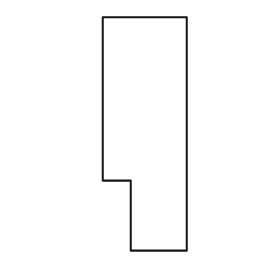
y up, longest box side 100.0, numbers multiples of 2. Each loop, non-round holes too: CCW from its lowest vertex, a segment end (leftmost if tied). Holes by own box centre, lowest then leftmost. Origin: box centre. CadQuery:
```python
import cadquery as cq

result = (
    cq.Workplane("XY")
    .moveTo(-6.0, -50.0)
    .lineTo(18.0, -50.0)
    .lineTo(18.0, 50.0)
    .lineTo(-18.0, 50.0)
    .lineTo(-18.0, -20.0)
    .lineTo(-6.0, -20.0)
    .close()
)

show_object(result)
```